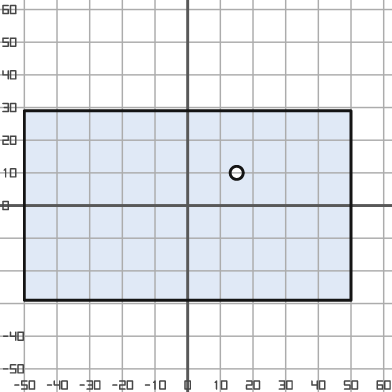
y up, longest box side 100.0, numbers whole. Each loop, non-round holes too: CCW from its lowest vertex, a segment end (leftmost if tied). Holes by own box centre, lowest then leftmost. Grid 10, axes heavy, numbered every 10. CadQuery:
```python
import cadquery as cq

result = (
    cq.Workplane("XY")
    .moveTo(-50.0, -29.0)
    .lineTo(50.0, -29.0)
    .lineTo(50.0, 29.0)
    .lineTo(-50.0, 29.0)
    .close()
    .moveTo(15.0, 10.0)
    .circle(2.0)
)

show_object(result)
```